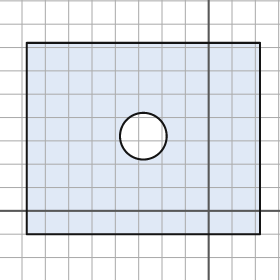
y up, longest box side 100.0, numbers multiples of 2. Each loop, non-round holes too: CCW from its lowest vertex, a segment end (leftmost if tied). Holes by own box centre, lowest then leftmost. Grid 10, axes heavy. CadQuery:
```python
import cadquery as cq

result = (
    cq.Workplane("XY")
    .moveTo(-78.0, -10.0)
    .lineTo(22.0, -10.0)
    .lineTo(22.0, 72.0)
    .lineTo(-78.0, 72.0)
    .close()
    .moveTo(-28.0, 32.0)
    .circle(10.0)
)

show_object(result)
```